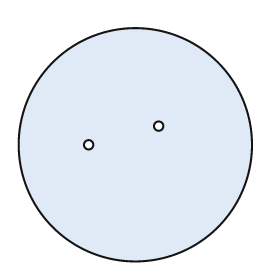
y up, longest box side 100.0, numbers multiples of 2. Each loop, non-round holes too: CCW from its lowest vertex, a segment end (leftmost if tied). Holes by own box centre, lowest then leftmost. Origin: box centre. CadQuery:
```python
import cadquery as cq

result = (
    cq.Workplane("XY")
    .moveTo(0.0, 0.0)
    .circle(50.0)
    .moveTo(-20.0, 0.0)
    .circle(2.0)
    .moveTo(10.0, 8.0)
    .circle(2.0)
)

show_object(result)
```